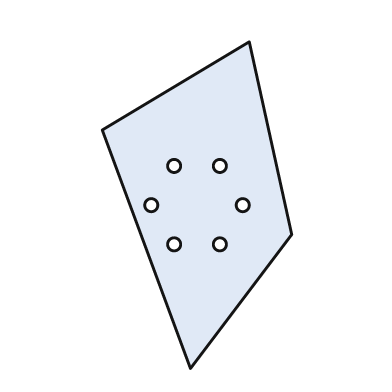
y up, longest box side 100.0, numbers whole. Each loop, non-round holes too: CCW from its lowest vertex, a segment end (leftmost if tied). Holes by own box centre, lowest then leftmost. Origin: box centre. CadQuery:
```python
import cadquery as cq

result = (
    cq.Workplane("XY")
    .moveTo(-2.0, -50.0)
    .lineTo(29.0, -9.0)
    .lineTo(16.0, 50.0)
    .lineTo(-29.0, 23.0)
    .close()
    .moveTo(-7.0, -12.0)
    .circle(2.0)
    .moveTo(7.0, -12.0)
    .circle(2.0)
    .moveTo(-14.0, 0.0)
    .circle(2.0)
    .moveTo(14.0, 0.0)
    .circle(2.0)
    .moveTo(-7.0, 12.0)
    .circle(2.0)
    .moveTo(7.0, 12.0)
    .circle(2.0)
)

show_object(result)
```